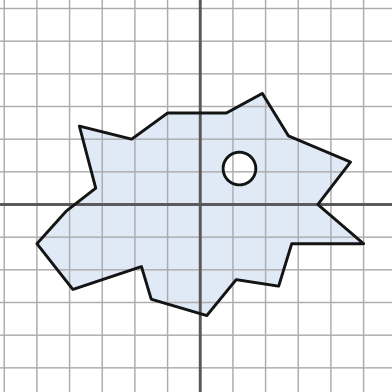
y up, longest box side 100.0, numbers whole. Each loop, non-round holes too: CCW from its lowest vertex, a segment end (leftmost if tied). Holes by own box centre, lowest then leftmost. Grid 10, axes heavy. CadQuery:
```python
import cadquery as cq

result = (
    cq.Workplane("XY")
    .moveTo(2.0, -34.0)
    .lineTo(11.0, -23.0)
    .lineTo(24.0, -25.0)
    .lineTo(28.0, -12.0)
    .lineTo(50.0, -12.0)
    .lineTo(36.0, 0.0)
    .lineTo(46.0, 13.0)
    .lineTo(27.0, 21.0)
    .lineTo(19.0, 34.0)
    .lineTo(8.0, 28.0)
    .lineTo(-10.0, 28.0)
    .lineTo(-21.0, 20.0)
    .lineTo(-37.0, 24.0)
    .lineTo(-32.0, 5.0)
    .lineTo(-41.0, -2.0)
    .lineTo(-50.0, -12.0)
    .lineTo(-39.0, -26.0)
    .lineTo(-18.0, -19.0)
    .lineTo(-15.0, -29.0)
    .close()
    .moveTo(12.0, 11.0)
    .circle(5.0)
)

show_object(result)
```